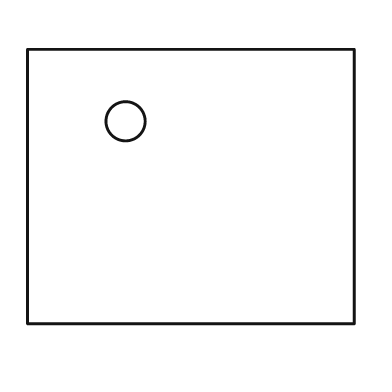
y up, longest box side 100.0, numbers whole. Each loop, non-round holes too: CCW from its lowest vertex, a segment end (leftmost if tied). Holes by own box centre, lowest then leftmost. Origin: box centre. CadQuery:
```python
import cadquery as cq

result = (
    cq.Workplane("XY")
    .moveTo(-50.0, -42.0)
    .lineTo(50.0, -42.0)
    .lineTo(50.0, 42.0)
    .lineTo(-50.0, 42.0)
    .close()
    .moveTo(-20.0, 20.0)
    .circle(6.0)
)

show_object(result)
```